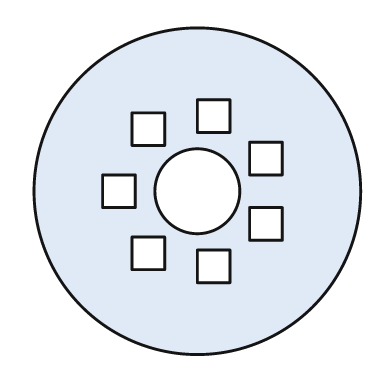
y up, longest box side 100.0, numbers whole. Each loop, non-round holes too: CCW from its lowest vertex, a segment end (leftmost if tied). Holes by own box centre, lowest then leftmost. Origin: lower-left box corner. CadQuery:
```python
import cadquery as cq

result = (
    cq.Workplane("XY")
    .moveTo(50.0, 50.0)
    .circle(50.0)
    .moveTo(50.0, 22.0)
    .lineTo(60.0, 22.0)
    .lineTo(60.0, 32.0)
    .lineTo(50.0, 32.0)
    .close()
    .moveTo(30.0, 26.0)
    .lineTo(40.0, 26.0)
    .lineTo(40.0, 36.0)
    .lineTo(30.0, 36.0)
    .close()
    .moveTo(66.0, 35.0)
    .lineTo(76.0, 35.0)
    .lineTo(76.0, 45.0)
    .lineTo(66.0, 45.0)
    .close()
    .moveTo(21.0, 45.0)
    .lineTo(31.0, 45.0)
    .lineTo(31.0, 55.0)
    .lineTo(21.0, 55.0)
    .close()
    .moveTo(50.0, 50.0)
    .circle(13.0)
    .moveTo(66.0, 55.0)
    .lineTo(76.0, 55.0)
    .lineTo(76.0, 65.0)
    .lineTo(66.0, 65.0)
    .close()
    .moveTo(30.0, 64.0)
    .lineTo(40.0, 64.0)
    .lineTo(40.0, 74.0)
    .lineTo(30.0, 74.0)
    .close()
    .moveTo(50.0, 68.0)
    .lineTo(60.0, 68.0)
    .lineTo(60.0, 78.0)
    .lineTo(50.0, 78.0)
    .close()
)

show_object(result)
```